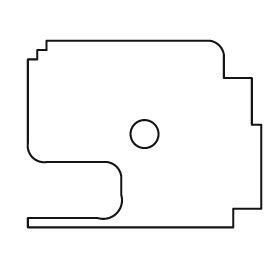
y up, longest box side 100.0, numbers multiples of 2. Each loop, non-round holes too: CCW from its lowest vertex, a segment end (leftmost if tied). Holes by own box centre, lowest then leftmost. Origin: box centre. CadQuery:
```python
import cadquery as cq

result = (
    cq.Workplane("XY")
    .moveTo(-50.0, -40.0)
    .lineTo(38.0, -40.0)
    .lineTo(38.0, -32.0)
    .lineTo(50.0, -32.0)
    .lineTo(50.0, 4.0)
    .lineTo(46.0, 4.0)
    .lineTo(46.0, 24.0)
    .lineTo(34.0, 24.0)
    .lineTo(34.0, 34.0)
    .threePointArc((32.0, 38.0), (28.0, 40.0))
    .lineTo(-42.0, 40.0)
    .lineTo(-42.0, 36.0)
    .lineTo(-46.0, 36.0)
    .lineTo(-46.0, 32.0)
    .lineTo(-50.0, 32.0)
    .lineTo(-50.0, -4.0)
    .threePointArc((-48.0, -10.0), (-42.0, -12.0))
    .lineTo(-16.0, -12.0)
    .threePointArc((-12.0, -14.0), (-10.0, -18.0))
    .lineTo(-10.0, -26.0)
    .threePointArc((-12.0, -34.0), (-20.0, -36.0))
    .lineTo(-50.0, -36.0)
    .close()
    .moveTo(0.0, 0.0)
    .circle(6.0)
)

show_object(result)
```